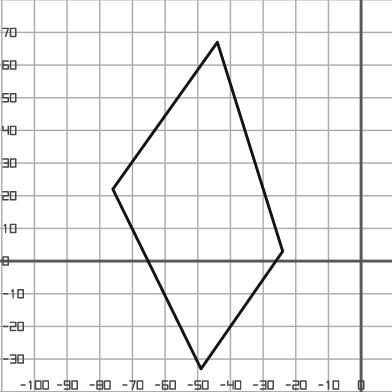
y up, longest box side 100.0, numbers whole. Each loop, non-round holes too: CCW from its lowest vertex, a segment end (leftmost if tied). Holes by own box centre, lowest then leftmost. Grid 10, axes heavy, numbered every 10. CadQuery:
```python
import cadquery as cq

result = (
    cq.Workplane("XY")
    .moveTo(-49.0, -33.0)
    .lineTo(-24.0, 3.0)
    .lineTo(-44.0, 67.0)
    .lineTo(-76.0, 22.0)
    .close()
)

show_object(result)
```